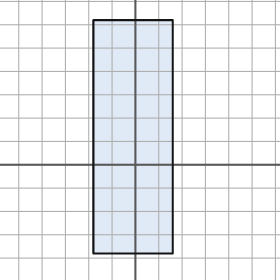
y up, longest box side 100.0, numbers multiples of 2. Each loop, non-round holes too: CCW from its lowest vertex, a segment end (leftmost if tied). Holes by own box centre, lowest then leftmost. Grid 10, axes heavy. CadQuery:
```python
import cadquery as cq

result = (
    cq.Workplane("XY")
    .moveTo(-18.0, -38.0)
    .lineTo(16.0, -38.0)
    .lineTo(16.0, 62.0)
    .lineTo(-18.0, 62.0)
    .close()
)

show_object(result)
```